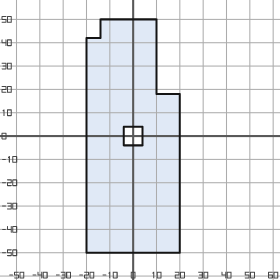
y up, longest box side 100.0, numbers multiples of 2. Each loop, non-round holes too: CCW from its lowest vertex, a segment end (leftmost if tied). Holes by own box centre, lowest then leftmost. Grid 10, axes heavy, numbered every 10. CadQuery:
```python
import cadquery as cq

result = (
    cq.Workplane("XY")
    .moveTo(-20.0, -50.0)
    .lineTo(20.0, -50.0)
    .lineTo(20.0, 18.0)
    .lineTo(10.0, 18.0)
    .lineTo(10.0, 50.0)
    .lineTo(-14.0, 50.0)
    .lineTo(-14.0, 42.0)
    .lineTo(-20.0, 42.0)
    .close()
    .moveTo(-4.0, -4.0)
    .lineTo(4.0, -4.0)
    .lineTo(4.0, 4.0)
    .lineTo(-4.0, 4.0)
    .close()
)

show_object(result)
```